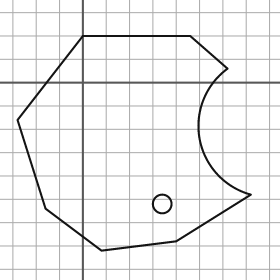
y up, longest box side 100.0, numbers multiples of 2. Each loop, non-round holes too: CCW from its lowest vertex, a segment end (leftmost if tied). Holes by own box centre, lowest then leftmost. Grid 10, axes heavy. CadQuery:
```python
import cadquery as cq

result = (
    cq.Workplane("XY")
    .moveTo(8.0, -72.0)
    .lineTo(40.0, -68.0)
    .lineTo(72.0, -48.0)
    .threePointArc((50.0, -24.0), (62.0, 6.0))
    .lineTo(46.0, 20.0)
    .lineTo(0.0, 20.0)
    .lineTo(-28.0, -16.0)
    .lineTo(-16.0, -54.0)
    .close()
    .moveTo(34.0, -52.0)
    .circle(4.0)
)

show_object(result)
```